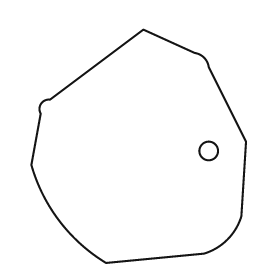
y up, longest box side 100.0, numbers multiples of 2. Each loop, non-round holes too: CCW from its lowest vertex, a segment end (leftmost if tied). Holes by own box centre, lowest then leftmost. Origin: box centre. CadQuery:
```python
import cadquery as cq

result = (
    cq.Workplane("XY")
    .moveTo(-14.0, -50.0)
    .lineTo(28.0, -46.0)
    .threePointArc((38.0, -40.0), (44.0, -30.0))
    .lineTo(46.0, 2.0)
    .lineTo(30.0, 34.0)
    .threePointArc((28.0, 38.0), (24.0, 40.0))
    .lineTo(2.0, 50.0)
    .lineTo(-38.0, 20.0)
    .threePointArc((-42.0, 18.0), (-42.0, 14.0))
    .lineTo(-46.0, -8.0)
    .threePointArc((-34.0, -32.0), (-14.0, -50.0))
    .close()
    .moveTo(30.0, -2.0)
    .circle(4.0)
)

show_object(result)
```